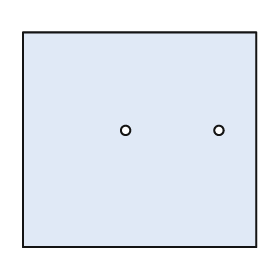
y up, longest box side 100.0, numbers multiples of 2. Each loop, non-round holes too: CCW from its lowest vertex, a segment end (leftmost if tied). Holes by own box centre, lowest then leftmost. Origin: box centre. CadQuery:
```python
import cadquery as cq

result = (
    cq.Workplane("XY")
    .moveTo(-50.0, -46.0)
    .lineTo(50.0, -46.0)
    .lineTo(50.0, 46.0)
    .lineTo(-50.0, 46.0)
    .close()
    .moveTo(-6.0, 4.0)
    .circle(2.0)
    .moveTo(34.0, 4.0)
    .circle(2.0)
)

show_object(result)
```